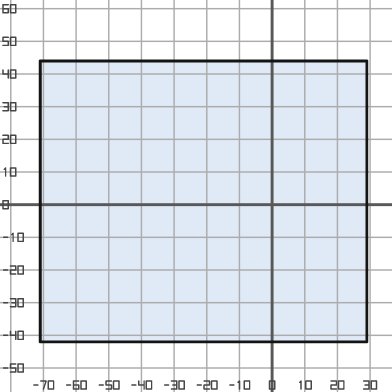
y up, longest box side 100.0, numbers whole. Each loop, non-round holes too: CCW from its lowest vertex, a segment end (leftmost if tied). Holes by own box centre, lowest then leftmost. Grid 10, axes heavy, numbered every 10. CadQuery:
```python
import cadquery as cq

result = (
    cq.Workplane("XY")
    .moveTo(-71.0, -42.0)
    .lineTo(29.0, -42.0)
    .lineTo(29.0, 44.0)
    .lineTo(-71.0, 44.0)
    .close()
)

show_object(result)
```